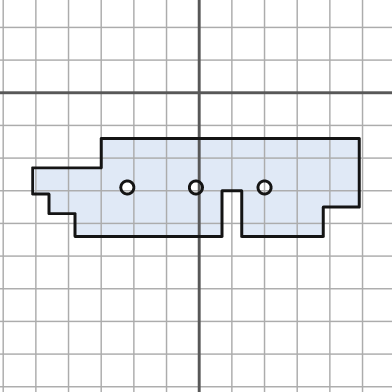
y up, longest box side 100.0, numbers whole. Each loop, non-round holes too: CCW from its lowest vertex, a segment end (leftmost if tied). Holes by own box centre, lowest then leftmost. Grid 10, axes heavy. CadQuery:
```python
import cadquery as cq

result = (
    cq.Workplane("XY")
    .moveTo(-38.0, -44.0)
    .lineTo(7.0, -44.0)
    .lineTo(7.0, -30.0)
    .lineTo(13.0, -30.0)
    .lineTo(13.0, -44.0)
    .lineTo(38.0, -44.0)
    .lineTo(38.0, -35.0)
    .lineTo(49.0, -35.0)
    .lineTo(49.0, -14.0)
    .lineTo(-30.0, -14.0)
    .lineTo(-30.0, -23.0)
    .lineTo(-51.0, -23.0)
    .lineTo(-51.0, -31.0)
    .lineTo(-46.0, -31.0)
    .lineTo(-46.0, -37.0)
    .lineTo(-38.0, -37.0)
    .close()
    .moveTo(-22.0, -29.0)
    .circle(2.0)
    .moveTo(-1.0, -29.0)
    .circle(2.0)
    .moveTo(20.0, -29.0)
    .circle(2.0)
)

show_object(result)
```